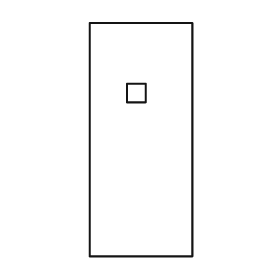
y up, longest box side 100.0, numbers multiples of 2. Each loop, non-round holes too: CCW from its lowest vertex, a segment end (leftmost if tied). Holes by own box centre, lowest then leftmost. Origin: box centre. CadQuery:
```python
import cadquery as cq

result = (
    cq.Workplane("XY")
    .moveTo(-22.0, -50.0)
    .lineTo(22.0, -50.0)
    .lineTo(22.0, 50.0)
    .lineTo(-22.0, 50.0)
    .close()
    .moveTo(-6.0, 16.0)
    .lineTo(2.0, 16.0)
    .lineTo(2.0, 24.0)
    .lineTo(-6.0, 24.0)
    .close()
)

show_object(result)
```